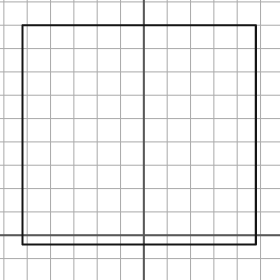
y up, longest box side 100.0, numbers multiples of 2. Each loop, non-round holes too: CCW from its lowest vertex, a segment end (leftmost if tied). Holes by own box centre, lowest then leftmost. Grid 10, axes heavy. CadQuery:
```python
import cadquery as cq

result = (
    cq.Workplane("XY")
    .moveTo(-52.0, -4.0)
    .lineTo(48.0, -4.0)
    .lineTo(48.0, 90.0)
    .lineTo(-52.0, 90.0)
    .close()
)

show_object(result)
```